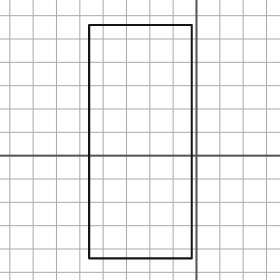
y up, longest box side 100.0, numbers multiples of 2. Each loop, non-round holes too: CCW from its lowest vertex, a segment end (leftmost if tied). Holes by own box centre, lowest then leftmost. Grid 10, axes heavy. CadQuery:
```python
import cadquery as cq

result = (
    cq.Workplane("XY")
    .moveTo(-46.0, -44.0)
    .lineTo(-2.0, -44.0)
    .lineTo(-2.0, 56.0)
    .lineTo(-46.0, 56.0)
    .close()
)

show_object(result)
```